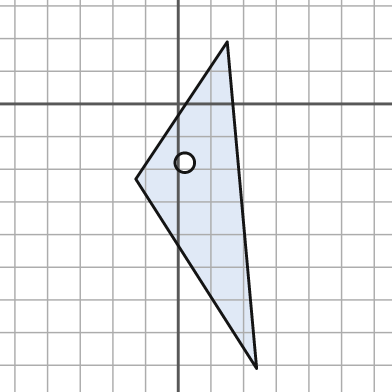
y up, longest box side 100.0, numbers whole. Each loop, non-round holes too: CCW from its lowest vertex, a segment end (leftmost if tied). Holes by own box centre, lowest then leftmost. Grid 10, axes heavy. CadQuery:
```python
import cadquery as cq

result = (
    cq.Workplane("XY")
    .moveTo(24.0, -81.0)
    .lineTo(15.0, 19.0)
    .lineTo(-13.0, -23.0)
    .close()
    .moveTo(2.0, -18.0)
    .circle(3.0)
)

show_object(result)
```